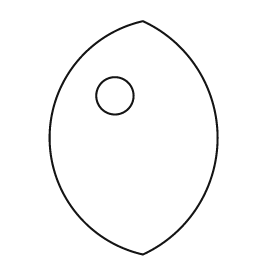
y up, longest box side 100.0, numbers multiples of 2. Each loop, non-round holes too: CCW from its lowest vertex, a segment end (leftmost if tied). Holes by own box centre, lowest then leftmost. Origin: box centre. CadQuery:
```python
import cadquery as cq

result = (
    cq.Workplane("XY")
    .moveTo(4.0, -50.0)
    .threePointArc((36.0, 0.0), (4.0, 50.0))
    .threePointArc((-36.0, 0.0), (4.0, -50.0))
    .close()
    .moveTo(-8.0, 18.0)
    .circle(8.0)
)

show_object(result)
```